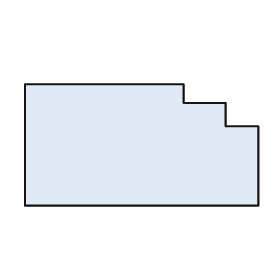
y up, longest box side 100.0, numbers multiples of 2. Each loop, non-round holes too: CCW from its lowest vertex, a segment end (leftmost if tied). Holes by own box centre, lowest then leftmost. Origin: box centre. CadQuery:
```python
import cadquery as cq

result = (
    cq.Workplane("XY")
    .moveTo(-50.0, -26.0)
    .lineTo(50.0, -26.0)
    .lineTo(50.0, 8.0)
    .lineTo(36.0, 8.0)
    .lineTo(36.0, 18.0)
    .lineTo(18.0, 18.0)
    .lineTo(18.0, 26.0)
    .lineTo(-50.0, 26.0)
    .close()
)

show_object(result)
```